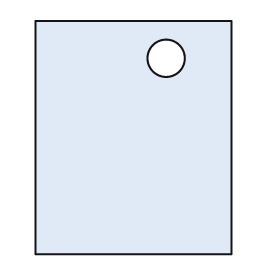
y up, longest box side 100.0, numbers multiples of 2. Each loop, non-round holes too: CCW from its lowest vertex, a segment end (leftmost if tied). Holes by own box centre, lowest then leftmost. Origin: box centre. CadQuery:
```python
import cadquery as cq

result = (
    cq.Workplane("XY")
    .moveTo(-42.0, -50.0)
    .lineTo(42.0, -50.0)
    .lineTo(42.0, 50.0)
    .lineTo(-42.0, 50.0)
    .close()
    .moveTo(14.0, 34.0)
    .circle(8.0)
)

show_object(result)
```